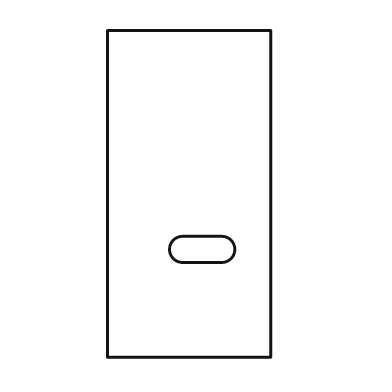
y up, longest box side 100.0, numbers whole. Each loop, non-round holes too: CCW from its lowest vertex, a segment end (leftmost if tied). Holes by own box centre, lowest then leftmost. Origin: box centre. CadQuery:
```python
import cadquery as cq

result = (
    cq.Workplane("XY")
    .moveTo(-25.0, -50.0)
    .lineTo(25.0, -50.0)
    .lineTo(25.0, 50.0)
    .lineTo(-25.0, 50.0)
    .close()
    .moveTo(-2.0, -21.0)
    .lineTo(10.0, -21.0)
    .threePointArc((14.0, -17.0), (10.0, -13.0))
    .lineTo(-2.0, -13.0)
    .threePointArc((-6.0, -17.0), (-2.0, -21.0))
    .close()
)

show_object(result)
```